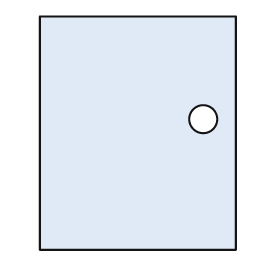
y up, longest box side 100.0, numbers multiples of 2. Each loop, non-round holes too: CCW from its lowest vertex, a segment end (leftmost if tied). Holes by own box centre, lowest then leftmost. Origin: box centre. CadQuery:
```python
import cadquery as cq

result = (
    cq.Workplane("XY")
    .moveTo(-42.0, -50.0)
    .lineTo(42.0, -50.0)
    .lineTo(42.0, 50.0)
    .lineTo(-42.0, 50.0)
    .close()
    .moveTo(28.0, 6.0)
    .circle(6.0)
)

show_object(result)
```